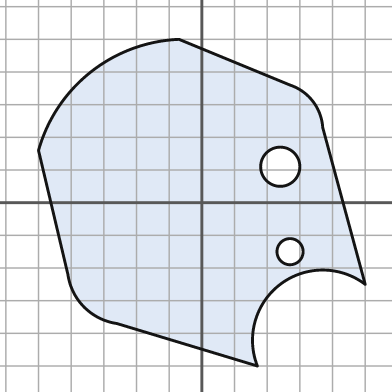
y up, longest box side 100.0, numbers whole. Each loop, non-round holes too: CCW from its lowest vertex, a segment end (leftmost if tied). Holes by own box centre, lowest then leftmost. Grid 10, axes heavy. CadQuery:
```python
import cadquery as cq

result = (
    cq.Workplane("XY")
    .moveTo(17.0, -50.0)
    .threePointArc((24.0, -25.0), (50.0, -25.0))
    .lineTo(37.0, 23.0)
    .threePointArc((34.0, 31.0), (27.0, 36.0))
    .lineTo(-7.0, 50.0)
    .threePointArc((-34.0, 40.0), (-50.0, 16.0))
    .lineTo(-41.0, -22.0)
    .threePointArc((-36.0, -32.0), (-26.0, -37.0))
    .close()
    .moveTo(27.0, -15.0)
    .circle(4.0)
    .moveTo(24.0, 11.0)
    .circle(6.0)
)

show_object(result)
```